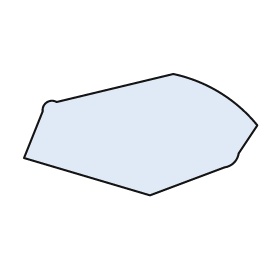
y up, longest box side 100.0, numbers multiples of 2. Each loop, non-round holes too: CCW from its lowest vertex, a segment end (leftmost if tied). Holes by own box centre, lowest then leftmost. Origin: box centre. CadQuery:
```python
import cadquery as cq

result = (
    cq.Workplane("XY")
    .moveTo(4.0, -26.0)
    .lineTo(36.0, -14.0)
    .threePointArc((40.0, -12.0), (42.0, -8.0))
    .lineTo(50.0, 4.0)
    .threePointArc((34.0, 18.0), (14.0, 26.0))
    .lineTo(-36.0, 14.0)
    .threePointArc((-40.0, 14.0), (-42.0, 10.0))
    .lineTo(-50.0, -10.0)
    .close()
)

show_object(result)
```